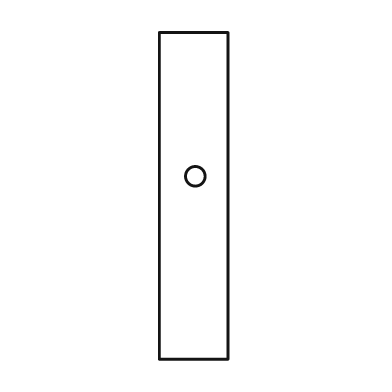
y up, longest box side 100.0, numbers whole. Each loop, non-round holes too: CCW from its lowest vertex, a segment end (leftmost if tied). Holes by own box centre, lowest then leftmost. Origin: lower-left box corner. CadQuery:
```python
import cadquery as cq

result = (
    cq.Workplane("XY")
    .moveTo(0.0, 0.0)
    .lineTo(21.0, 0.0)
    .lineTo(21.0, 100.0)
    .lineTo(0.0, 100.0)
    .close()
    .moveTo(11.0, 56.0)
    .circle(3.0)
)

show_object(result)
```